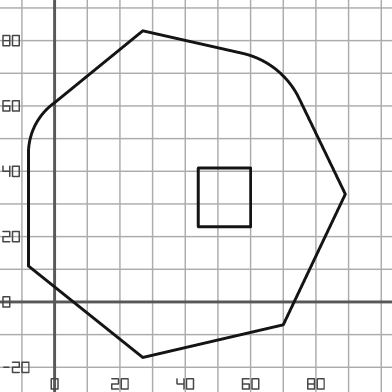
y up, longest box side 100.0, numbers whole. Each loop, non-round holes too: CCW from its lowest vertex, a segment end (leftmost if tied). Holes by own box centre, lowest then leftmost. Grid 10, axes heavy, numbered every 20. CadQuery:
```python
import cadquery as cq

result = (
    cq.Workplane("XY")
    .moveTo(27.0, -17.0)
    .lineTo(70.0, -7.0)
    .lineTo(89.0, 33.0)
    .lineTo(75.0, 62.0)
    .threePointArc((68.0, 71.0), (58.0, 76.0))
    .lineTo(27.0, 83.0)
    .lineTo(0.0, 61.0)
    .threePointArc((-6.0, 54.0), (-8.0, 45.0))
    .lineTo(-8.0, 11.0)
    .close()
    .moveTo(44.0, 23.0)
    .lineTo(60.0, 23.0)
    .lineTo(60.0, 41.0)
    .lineTo(44.0, 41.0)
    .close()
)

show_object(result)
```